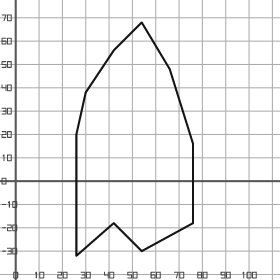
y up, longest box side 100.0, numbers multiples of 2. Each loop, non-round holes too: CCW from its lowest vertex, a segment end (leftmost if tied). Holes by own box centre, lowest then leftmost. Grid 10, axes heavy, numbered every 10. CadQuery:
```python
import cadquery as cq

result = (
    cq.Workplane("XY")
    .moveTo(26.0, -32.0)
    .lineTo(42.0, -18.0)
    .lineTo(54.0, -30.0)
    .lineTo(76.0, -18.0)
    .lineTo(76.0, 16.0)
    .lineTo(66.0, 48.0)
    .lineTo(54.0, 68.0)
    .lineTo(42.0, 56.0)
    .lineTo(30.0, 38.0)
    .lineTo(26.0, 20.0)
    .close()
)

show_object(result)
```